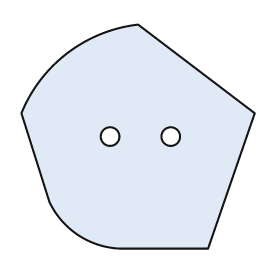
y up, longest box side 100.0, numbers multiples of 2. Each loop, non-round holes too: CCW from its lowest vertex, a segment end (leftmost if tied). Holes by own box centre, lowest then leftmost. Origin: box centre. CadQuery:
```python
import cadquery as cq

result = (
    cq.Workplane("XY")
    .moveTo(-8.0, -48.0)
    .lineTo(30.0, -48.0)
    .lineTo(50.0, 10.0)
    .lineTo(0.0, 48.0)
    .threePointArc((-30.0, 36.0), (-50.0, 10.0))
    .lineTo(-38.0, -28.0)
    .threePointArc((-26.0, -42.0), (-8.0, -48.0))
    .close()
    .moveTo(-12.0, 0.0)
    .circle(4.0)
    .moveTo(14.0, 0.0)
    .circle(4.0)
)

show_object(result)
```